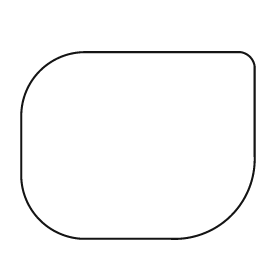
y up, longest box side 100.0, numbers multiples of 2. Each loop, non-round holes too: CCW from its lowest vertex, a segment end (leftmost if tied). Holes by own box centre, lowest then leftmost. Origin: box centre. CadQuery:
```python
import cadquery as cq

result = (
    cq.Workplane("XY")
    .moveTo(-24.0, -40.0)
    .lineTo(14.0, -40.0)
    .threePointArc((40.0, -30.0), (50.0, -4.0))
    .lineTo(50.0, 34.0)
    .threePointArc((48.0, 38.0), (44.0, 40.0))
    .lineTo(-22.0, 40.0)
    .threePointArc((-42.0, 32.0), (-50.0, 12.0))
    .lineTo(-50.0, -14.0)
    .threePointArc((-42.0, -32.0), (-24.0, -40.0))
    .close()
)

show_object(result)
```